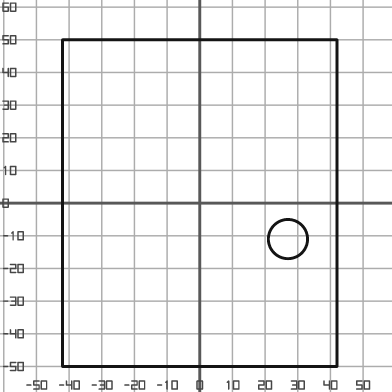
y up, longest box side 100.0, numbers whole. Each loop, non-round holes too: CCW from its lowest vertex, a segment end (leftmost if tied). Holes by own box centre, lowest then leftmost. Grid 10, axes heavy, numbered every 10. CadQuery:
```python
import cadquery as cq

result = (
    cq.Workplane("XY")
    .moveTo(-42.0, -50.0)
    .lineTo(42.0, -50.0)
    .lineTo(42.0, 50.0)
    .lineTo(-42.0, 50.0)
    .close()
    .moveTo(27.0, -11.0)
    .circle(6.0)
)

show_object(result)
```